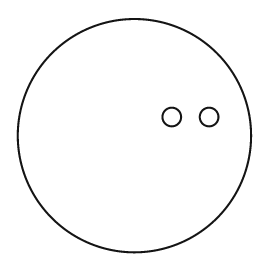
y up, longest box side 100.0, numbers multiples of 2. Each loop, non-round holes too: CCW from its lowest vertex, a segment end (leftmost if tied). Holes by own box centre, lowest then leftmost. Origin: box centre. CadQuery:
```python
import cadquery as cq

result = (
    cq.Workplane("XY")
    .moveTo(0.0, 0.0)
    .circle(50.0)
    .moveTo(16.0, 8.0)
    .circle(4.0)
    .moveTo(32.0, 8.0)
    .circle(4.0)
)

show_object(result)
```